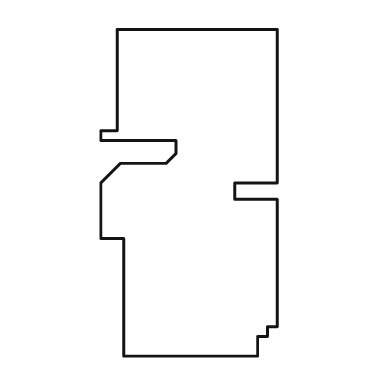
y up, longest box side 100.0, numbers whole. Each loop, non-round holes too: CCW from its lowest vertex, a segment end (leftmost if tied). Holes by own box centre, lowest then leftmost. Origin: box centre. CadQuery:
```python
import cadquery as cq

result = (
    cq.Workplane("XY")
    .moveTo(-20.0, -50.0)
    .lineTo(21.0, -50.0)
    .lineTo(21.0, -44.0)
    .lineTo(24.0, -44.0)
    .lineTo(24.0, -41.0)
    .lineTo(27.0, -41.0)
    .lineTo(27.0, -2.0)
    .lineTo(14.0, -2.0)
    .lineTo(14.0, 3.0)
    .lineTo(27.0, 3.0)
    .lineTo(27.0, 50.0)
    .lineTo(-22.0, 50.0)
    .lineTo(-22.0, 19.0)
    .lineTo(-27.0, 19.0)
    .lineTo(-27.0, 16.0)
    .lineTo(-4.0, 16.0)
    .lineTo(-4.0, 12.0)
    .lineTo(-7.0, 9.0)
    .lineTo(-21.0, 9.0)
    .lineTo(-27.0, 3.0)
    .lineTo(-27.0, -14.0)
    .lineTo(-20.0, -14.0)
    .close()
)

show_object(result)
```